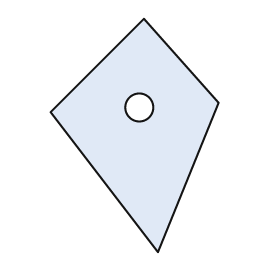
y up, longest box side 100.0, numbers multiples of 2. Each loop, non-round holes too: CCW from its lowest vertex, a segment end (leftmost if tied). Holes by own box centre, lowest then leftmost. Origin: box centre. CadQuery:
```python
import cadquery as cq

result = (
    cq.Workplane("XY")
    .moveTo(10.0, -50.0)
    .lineTo(36.0, 14.0)
    .lineTo(4.0, 50.0)
    .lineTo(-36.0, 10.0)
    .close()
    .moveTo(2.0, 12.0)
    .circle(6.0)
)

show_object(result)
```